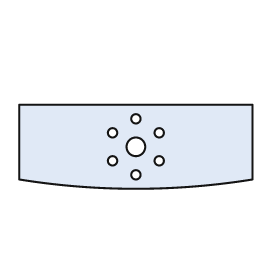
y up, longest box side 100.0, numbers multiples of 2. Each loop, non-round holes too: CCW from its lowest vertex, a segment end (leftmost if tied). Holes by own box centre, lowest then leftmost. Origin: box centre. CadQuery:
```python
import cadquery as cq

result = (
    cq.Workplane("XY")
    .moveTo(-50.0, -14.0)
    .threePointArc((0.0, -18.0), (50.0, -14.0))
    .lineTo(50.0, 18.0)
    .lineTo(-50.0, 18.0)
    .close()
    .moveTo(0.0, -12.0)
    .circle(2.0)
    .moveTo(-10.0, -6.0)
    .circle(2.0)
    .moveTo(10.0, -6.0)
    .circle(2.0)
    .moveTo(0.0, 0.0)
    .circle(4.0)
    .moveTo(-10.0, 6.0)
    .circle(2.0)
    .moveTo(10.0, 6.0)
    .circle(2.0)
    .moveTo(0.0, 12.0)
    .circle(2.0)
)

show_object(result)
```